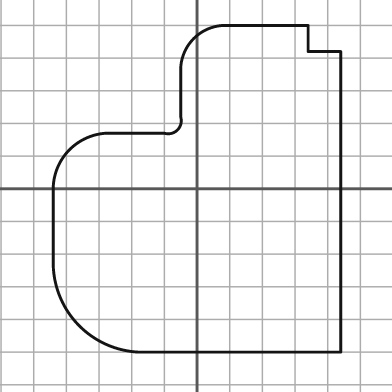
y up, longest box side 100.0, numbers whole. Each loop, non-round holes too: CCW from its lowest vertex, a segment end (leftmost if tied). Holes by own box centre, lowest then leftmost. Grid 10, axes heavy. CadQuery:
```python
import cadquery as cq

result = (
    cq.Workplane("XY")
    .moveTo(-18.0, -50.0)
    .lineTo(44.0, -50.0)
    .lineTo(44.0, 42.0)
    .lineTo(34.0, 42.0)
    .lineTo(34.0, 50.0)
    .lineTo(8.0, 50.0)
    .threePointArc((-1.0, 46.0), (-5.0, 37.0))
    .lineTo(-5.0, 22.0)
    .threePointArc((-6.0, 18.0), (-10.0, 17.0))
    .lineTo(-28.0, 17.0)
    .threePointArc((-39.0, 12.0), (-44.0, 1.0))
    .lineTo(-44.0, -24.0)
    .threePointArc((-36.0, -42.0), (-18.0, -50.0))
    .close()
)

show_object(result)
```